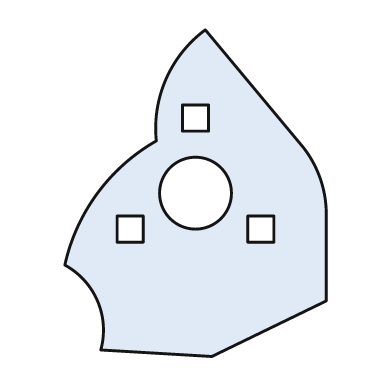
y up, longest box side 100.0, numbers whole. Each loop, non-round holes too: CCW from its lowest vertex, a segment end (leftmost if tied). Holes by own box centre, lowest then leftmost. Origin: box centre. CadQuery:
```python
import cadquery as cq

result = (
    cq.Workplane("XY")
    .moveTo(5.0, -50.0)
    .lineTo(40.0, -33.0)
    .lineTo(40.0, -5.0)
    .threePointArc((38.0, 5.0), (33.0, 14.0))
    .lineTo(3.0, 50.0)
    .threePointArc((-9.0, 35.0), (-12.0, 16.0))
    .threePointArc((-30.0, 0.0), (-40.0, -22.0))
    .threePointArc((-30.0, -33.0), (-29.0, -48.0))
    .close()
    .moveTo(-24.0, -15.0)
    .lineTo(-16.0, -15.0)
    .lineTo(-16.0, -7.0)
    .lineTo(-24.0, -7.0)
    .close()
    .moveTo(16.0, -15.0)
    .lineTo(24.0, -15.0)
    .lineTo(24.0, -7.0)
    .lineTo(16.0, -7.0)
    .close()
    .moveTo(0.0, 0.0)
    .circle(11.0)
    .moveTo(-4.0, 19.0)
    .lineTo(4.0, 19.0)
    .lineTo(4.0, 27.0)
    .lineTo(-4.0, 27.0)
    .close()
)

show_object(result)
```